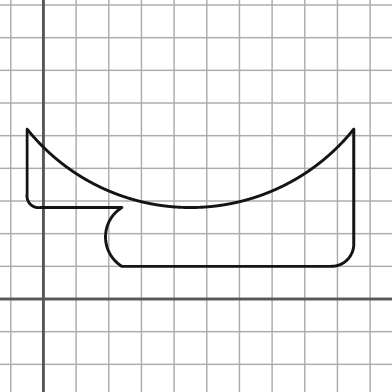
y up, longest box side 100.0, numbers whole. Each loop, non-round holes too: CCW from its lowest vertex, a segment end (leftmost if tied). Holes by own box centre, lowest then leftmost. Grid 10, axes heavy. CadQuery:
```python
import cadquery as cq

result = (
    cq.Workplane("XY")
    .moveTo(24.0, 10.0)
    .lineTo(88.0, 10.0)
    .threePointArc((93.0, 12.0), (95.0, 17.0))
    .lineTo(95.0, 52.0)
    .threePointArc((45.0, 28.0), (-5.0, 52.0))
    .lineTo(-5.0, 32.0)
    .threePointArc((-4.0, 29.0), (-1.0, 28.0))
    .lineTo(24.0, 28.0)
    .threePointArc((19.0, 19.0), (24.0, 10.0))
    .close()
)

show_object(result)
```